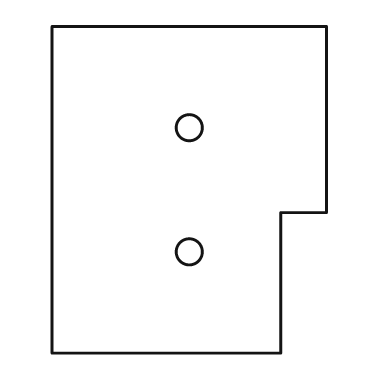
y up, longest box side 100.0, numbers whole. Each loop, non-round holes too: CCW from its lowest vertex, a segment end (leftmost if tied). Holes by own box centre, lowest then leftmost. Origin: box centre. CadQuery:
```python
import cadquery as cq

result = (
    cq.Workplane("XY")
    .moveTo(-42.0, -50.0)
    .lineTo(28.0, -50.0)
    .lineTo(28.0, -7.0)
    .lineTo(42.0, -7.0)
    .lineTo(42.0, 50.0)
    .lineTo(-42.0, 50.0)
    .close()
    .moveTo(0.0, -19.0)
    .circle(4.0)
    .moveTo(0.0, 19.0)
    .circle(4.0)
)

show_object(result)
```